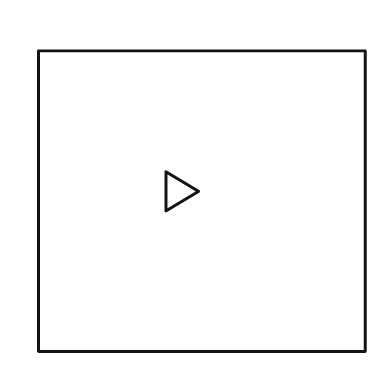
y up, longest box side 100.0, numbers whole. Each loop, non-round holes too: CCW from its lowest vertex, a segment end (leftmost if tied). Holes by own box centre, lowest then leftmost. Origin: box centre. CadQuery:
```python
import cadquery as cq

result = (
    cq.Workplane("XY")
    .moveTo(-50.0, -46.0)
    .lineTo(50.0, -46.0)
    .lineTo(50.0, 46.0)
    .lineTo(-50.0, 46.0)
    .close()
    .moveTo(-11.0, -3.0)
    .lineTo(-1.0, 3.0)
    .lineTo(-11.0, 9.0)
    .close()
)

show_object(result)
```